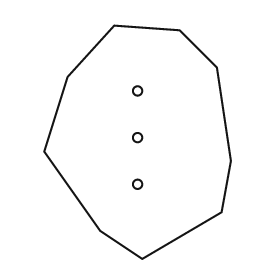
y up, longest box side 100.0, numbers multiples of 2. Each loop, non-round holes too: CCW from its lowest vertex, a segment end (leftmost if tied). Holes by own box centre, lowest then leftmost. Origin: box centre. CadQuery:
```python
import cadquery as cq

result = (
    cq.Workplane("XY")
    .moveTo(2.0, -50.0)
    .lineTo(36.0, -30.0)
    .lineTo(40.0, -8.0)
    .lineTo(34.0, 32.0)
    .lineTo(18.0, 48.0)
    .lineTo(-10.0, 50.0)
    .lineTo(-30.0, 28.0)
    .lineTo(-40.0, -4.0)
    .lineTo(-16.0, -38.0)
    .close()
    .moveTo(0.0, -18.0)
    .circle(2.0)
    .moveTo(0.0, 2.0)
    .circle(2.0)
    .moveTo(0.0, 22.0)
    .circle(2.0)
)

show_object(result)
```